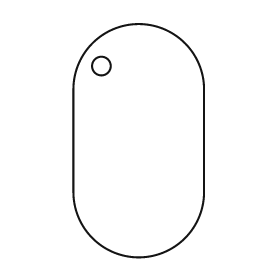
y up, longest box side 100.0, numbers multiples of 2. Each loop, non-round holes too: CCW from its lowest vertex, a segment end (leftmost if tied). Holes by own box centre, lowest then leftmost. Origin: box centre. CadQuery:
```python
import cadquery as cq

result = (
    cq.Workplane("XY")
    .moveTo(-28.0, -22.0)
    .threePointArc((0.0, -50.0), (28.0, -22.0))
    .lineTo(28.0, 22.0)
    .threePointArc((0.0, 50.0), (-28.0, 22.0))
    .close()
    .moveTo(-16.0, 32.0)
    .circle(4.0)
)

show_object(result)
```